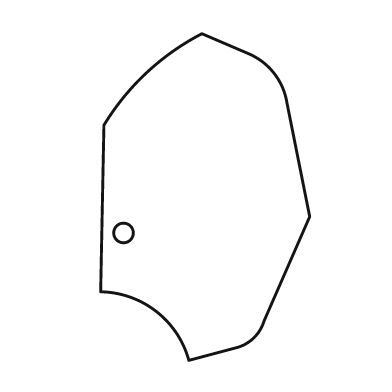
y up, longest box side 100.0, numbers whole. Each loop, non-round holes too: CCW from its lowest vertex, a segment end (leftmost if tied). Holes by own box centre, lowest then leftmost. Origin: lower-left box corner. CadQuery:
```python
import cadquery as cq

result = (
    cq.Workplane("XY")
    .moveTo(27.0, 0.0)
    .lineTo(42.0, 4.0)
    .threePointArc((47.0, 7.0), (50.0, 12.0))
    .lineTo(64.0, 44.0)
    .lineTo(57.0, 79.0)
    .threePointArc((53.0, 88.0), (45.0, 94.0))
    .lineTo(31.0, 100.0)
    .threePointArc((14.0, 88.0), (1.0, 72.0))
    .lineTo(0.0, 21.0)
    .threePointArc((17.0, 15.0), (27.0, 0.0))
    .close()
    .moveTo(7.0, 39.0)
    .circle(3.0)
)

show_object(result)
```